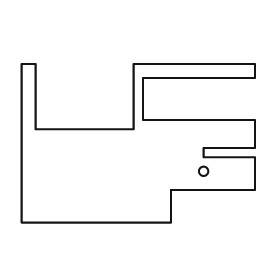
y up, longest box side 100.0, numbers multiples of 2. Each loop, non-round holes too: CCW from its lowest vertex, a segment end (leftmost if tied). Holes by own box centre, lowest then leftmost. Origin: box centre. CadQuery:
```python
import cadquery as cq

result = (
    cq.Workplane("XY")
    .moveTo(-50.0, -34.0)
    .lineTo(14.0, -34.0)
    .lineTo(14.0, -20.0)
    .lineTo(50.0, -20.0)
    .lineTo(50.0, -6.0)
    .lineTo(28.0, -6.0)
    .lineTo(28.0, -2.0)
    .lineTo(50.0, -2.0)
    .lineTo(50.0, 10.0)
    .lineTo(2.0, 10.0)
    .lineTo(2.0, 28.0)
    .lineTo(50.0, 28.0)
    .lineTo(50.0, 34.0)
    .lineTo(-2.0, 34.0)
    .lineTo(-2.0, 6.0)
    .lineTo(-44.0, 6.0)
    .lineTo(-44.0, 34.0)
    .lineTo(-50.0, 34.0)
    .close()
    .moveTo(28.0, -12.0)
    .circle(2.0)
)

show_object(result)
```